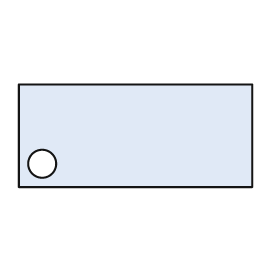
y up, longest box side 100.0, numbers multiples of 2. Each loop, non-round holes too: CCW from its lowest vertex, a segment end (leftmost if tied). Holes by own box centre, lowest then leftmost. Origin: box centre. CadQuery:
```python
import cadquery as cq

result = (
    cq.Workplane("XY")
    .moveTo(-50.0, -22.0)
    .lineTo(50.0, -22.0)
    .lineTo(50.0, 22.0)
    .lineTo(-50.0, 22.0)
    .close()
    .moveTo(-40.0, -12.0)
    .circle(6.0)
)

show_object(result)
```